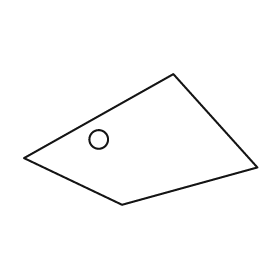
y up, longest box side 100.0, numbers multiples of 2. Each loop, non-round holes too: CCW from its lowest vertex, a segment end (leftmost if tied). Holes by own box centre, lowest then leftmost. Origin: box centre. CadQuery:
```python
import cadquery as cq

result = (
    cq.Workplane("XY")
    .moveTo(-8.0, -28.0)
    .lineTo(50.0, -12.0)
    .lineTo(14.0, 28.0)
    .lineTo(-50.0, -8.0)
    .close()
    .moveTo(-18.0, 0.0)
    .circle(4.0)
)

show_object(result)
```